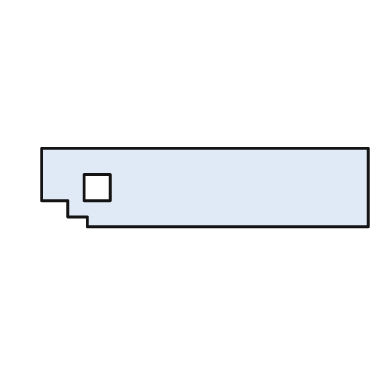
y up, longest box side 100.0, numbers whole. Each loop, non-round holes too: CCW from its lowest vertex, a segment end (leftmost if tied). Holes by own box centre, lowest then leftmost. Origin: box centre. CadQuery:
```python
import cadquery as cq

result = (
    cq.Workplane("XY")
    .moveTo(-36.0, -12.0)
    .lineTo(50.0, -12.0)
    .lineTo(50.0, 12.0)
    .lineTo(-50.0, 12.0)
    .lineTo(-50.0, -4.0)
    .lineTo(-42.0, -4.0)
    .lineTo(-42.0, -9.0)
    .lineTo(-36.0, -9.0)
    .close()
    .moveTo(-37.0, -4.0)
    .lineTo(-29.0, -4.0)
    .lineTo(-29.0, 4.0)
    .lineTo(-37.0, 4.0)
    .close()
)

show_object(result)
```